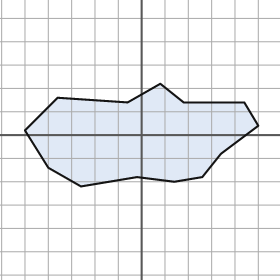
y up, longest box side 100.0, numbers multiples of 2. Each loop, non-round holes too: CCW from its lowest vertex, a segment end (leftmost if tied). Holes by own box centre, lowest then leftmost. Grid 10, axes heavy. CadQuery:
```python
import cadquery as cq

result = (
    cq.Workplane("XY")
    .moveTo(-26.0, -22.0)
    .lineTo(-2.0, -18.0)
    .lineTo(14.0, -20.0)
    .lineTo(26.0, -18.0)
    .lineTo(34.0, -8.0)
    .lineTo(50.0, 4.0)
    .lineTo(44.0, 14.0)
    .lineTo(18.0, 14.0)
    .lineTo(8.0, 22.0)
    .lineTo(-6.0, 14.0)
    .lineTo(-36.0, 16.0)
    .lineTo(-50.0, 2.0)
    .lineTo(-40.0, -14.0)
    .close()
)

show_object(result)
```